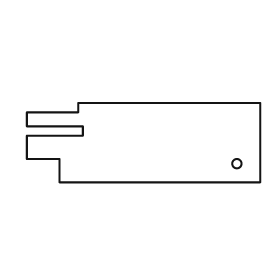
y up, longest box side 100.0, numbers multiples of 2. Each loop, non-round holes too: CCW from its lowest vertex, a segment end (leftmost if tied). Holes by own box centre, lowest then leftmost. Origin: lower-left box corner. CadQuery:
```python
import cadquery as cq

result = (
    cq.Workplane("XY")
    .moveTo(14.0, 0.0)
    .lineTo(100.0, 0.0)
    .lineTo(100.0, 34.0)
    .lineTo(22.0, 34.0)
    .lineTo(22.0, 30.0)
    .lineTo(0.0, 30.0)
    .lineTo(0.0, 24.0)
    .lineTo(24.0, 24.0)
    .lineTo(24.0, 20.0)
    .lineTo(0.0, 20.0)
    .lineTo(0.0, 10.0)
    .lineTo(14.0, 10.0)
    .close()
    .moveTo(90.0, 8.0)
    .circle(2.0)
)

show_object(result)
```